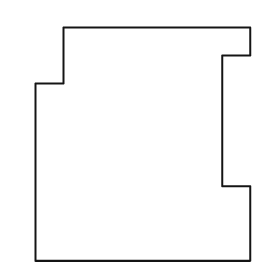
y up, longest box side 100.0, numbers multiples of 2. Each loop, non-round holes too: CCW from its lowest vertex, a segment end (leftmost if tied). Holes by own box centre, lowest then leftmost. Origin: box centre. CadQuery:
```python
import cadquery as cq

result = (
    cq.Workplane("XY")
    .moveTo(-46.0, -50.0)
    .lineTo(46.0, -50.0)
    .lineTo(46.0, -18.0)
    .lineTo(34.0, -18.0)
    .lineTo(34.0, 38.0)
    .lineTo(46.0, 38.0)
    .lineTo(46.0, 50.0)
    .lineTo(-34.0, 50.0)
    .lineTo(-34.0, 26.0)
    .lineTo(-46.0, 26.0)
    .close()
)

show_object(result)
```